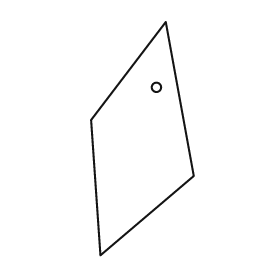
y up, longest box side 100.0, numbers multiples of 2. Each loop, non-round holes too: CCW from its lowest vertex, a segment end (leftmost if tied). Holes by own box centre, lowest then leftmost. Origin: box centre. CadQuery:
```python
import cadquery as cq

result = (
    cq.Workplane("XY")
    .moveTo(-18.0, -50.0)
    .lineTo(22.0, -16.0)
    .lineTo(10.0, 50.0)
    .lineTo(-22.0, 8.0)
    .close()
    .moveTo(6.0, 22.0)
    .circle(2.0)
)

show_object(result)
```